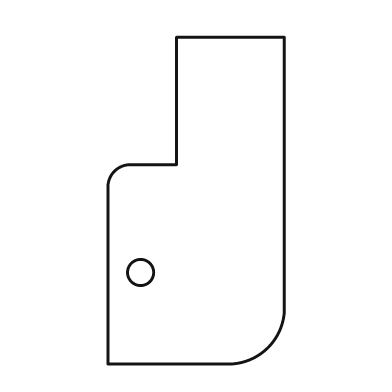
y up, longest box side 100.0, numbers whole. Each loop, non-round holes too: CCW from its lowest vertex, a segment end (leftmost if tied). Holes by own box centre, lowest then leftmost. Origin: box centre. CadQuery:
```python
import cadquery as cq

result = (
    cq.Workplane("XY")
    .moveTo(-27.0, -50.0)
    .lineTo(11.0, -50.0)
    .threePointArc((22.0, -45.0), (27.0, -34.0))
    .lineTo(27.0, 50.0)
    .lineTo(-6.0, 50.0)
    .lineTo(-6.0, 11.0)
    .lineTo(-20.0, 11.0)
    .threePointArc((-25.0, 9.0), (-27.0, 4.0))
    .close()
    .moveTo(-17.0, -22.0)
    .circle(4.0)
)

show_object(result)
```